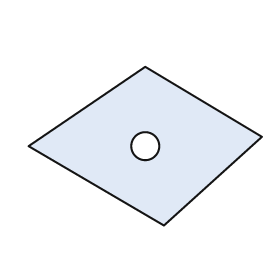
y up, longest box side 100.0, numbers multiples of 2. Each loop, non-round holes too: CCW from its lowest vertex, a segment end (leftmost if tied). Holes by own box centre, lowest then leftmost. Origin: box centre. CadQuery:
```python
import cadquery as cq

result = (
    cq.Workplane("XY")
    .moveTo(8.0, -34.0)
    .lineTo(50.0, 4.0)
    .lineTo(0.0, 34.0)
    .lineTo(-50.0, 0.0)
    .close()
    .moveTo(0.0, 0.0)
    .circle(6.0)
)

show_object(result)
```